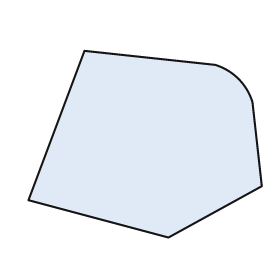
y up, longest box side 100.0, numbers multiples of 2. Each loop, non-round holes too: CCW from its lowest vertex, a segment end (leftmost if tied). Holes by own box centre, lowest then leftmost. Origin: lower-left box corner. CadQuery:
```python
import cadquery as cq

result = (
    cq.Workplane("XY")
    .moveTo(60.0, 0.0)
    .lineTo(100.0, 22.0)
    .lineTo(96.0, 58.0)
    .threePointArc((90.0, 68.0), (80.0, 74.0))
    .lineTo(24.0, 80.0)
    .lineTo(0.0, 16.0)
    .close()
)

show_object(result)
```